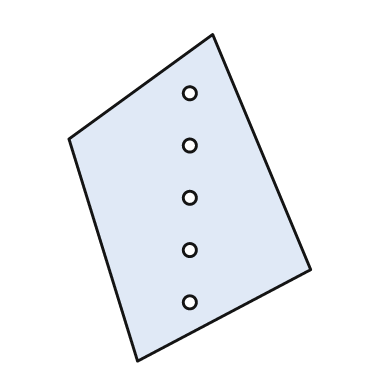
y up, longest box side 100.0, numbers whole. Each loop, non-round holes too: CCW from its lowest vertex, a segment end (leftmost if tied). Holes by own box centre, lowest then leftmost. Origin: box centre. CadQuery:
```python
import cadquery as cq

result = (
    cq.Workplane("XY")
    .moveTo(-16.0, -50.0)
    .lineTo(37.0, -22.0)
    .lineTo(7.0, 50.0)
    .lineTo(-37.0, 18.0)
    .close()
    .moveTo(0.0, -32.0)
    .circle(2.0)
    .moveTo(0.0, -16.0)
    .circle(2.0)
    .moveTo(0.0, 0.0)
    .circle(2.0)
    .moveTo(0.0, 16.0)
    .circle(2.0)
    .moveTo(0.0, 32.0)
    .circle(2.0)
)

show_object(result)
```